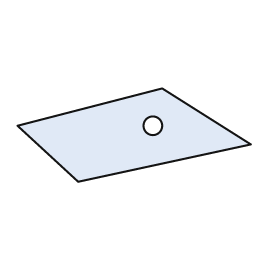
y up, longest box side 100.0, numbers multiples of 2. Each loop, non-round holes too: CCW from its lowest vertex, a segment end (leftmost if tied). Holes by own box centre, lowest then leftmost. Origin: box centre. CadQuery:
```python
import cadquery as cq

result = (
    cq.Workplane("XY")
    .moveTo(-24.0, -20.0)
    .lineTo(50.0, -4.0)
    .lineTo(12.0, 20.0)
    .lineTo(-50.0, 4.0)
    .close()
    .moveTo(8.0, 4.0)
    .circle(4.0)
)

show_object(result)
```